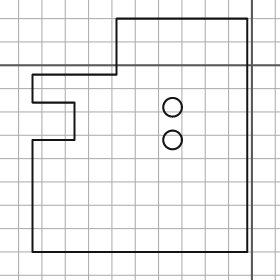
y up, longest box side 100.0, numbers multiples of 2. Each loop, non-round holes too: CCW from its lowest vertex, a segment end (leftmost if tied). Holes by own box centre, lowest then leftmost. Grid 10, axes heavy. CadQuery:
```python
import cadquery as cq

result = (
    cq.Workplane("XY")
    .moveTo(-94.0, -80.0)
    .lineTo(-2.0, -80.0)
    .lineTo(-2.0, 20.0)
    .lineTo(-58.0, 20.0)
    .lineTo(-58.0, -4.0)
    .lineTo(-94.0, -4.0)
    .lineTo(-94.0, -16.0)
    .lineTo(-76.0, -16.0)
    .lineTo(-76.0, -32.0)
    .lineTo(-94.0, -32.0)
    .close()
    .moveTo(-34.0, -32.0)
    .circle(4.0)
    .moveTo(-34.0, -18.0)
    .circle(4.0)
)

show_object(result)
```